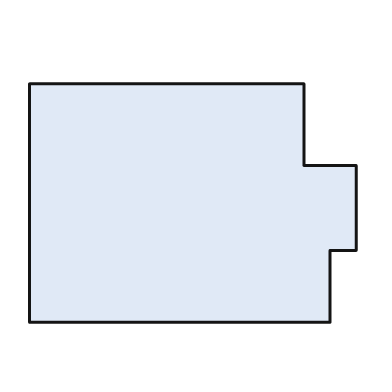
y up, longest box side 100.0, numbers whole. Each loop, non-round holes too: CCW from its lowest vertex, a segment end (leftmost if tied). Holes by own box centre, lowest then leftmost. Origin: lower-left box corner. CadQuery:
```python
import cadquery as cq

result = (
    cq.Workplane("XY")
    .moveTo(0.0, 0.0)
    .lineTo(92.0, 0.0)
    .lineTo(92.0, 22.0)
    .lineTo(100.0, 22.0)
    .lineTo(100.0, 48.0)
    .lineTo(84.0, 48.0)
    .lineTo(84.0, 73.0)
    .lineTo(0.0, 73.0)
    .close()
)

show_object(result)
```